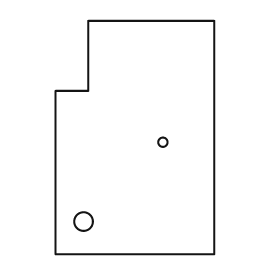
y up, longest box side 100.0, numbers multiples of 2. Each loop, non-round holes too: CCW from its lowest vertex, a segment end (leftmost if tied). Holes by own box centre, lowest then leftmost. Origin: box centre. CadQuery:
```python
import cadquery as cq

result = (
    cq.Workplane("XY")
    .moveTo(-34.0, -50.0)
    .lineTo(34.0, -50.0)
    .lineTo(34.0, 50.0)
    .lineTo(-20.0, 50.0)
    .lineTo(-20.0, 20.0)
    .lineTo(-34.0, 20.0)
    .close()
    .moveTo(-22.0, -36.0)
    .circle(4.0)
    .moveTo(12.0, -2.0)
    .circle(2.0)
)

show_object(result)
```